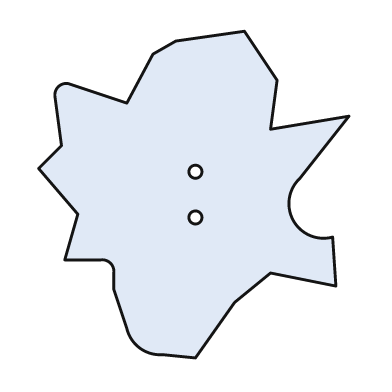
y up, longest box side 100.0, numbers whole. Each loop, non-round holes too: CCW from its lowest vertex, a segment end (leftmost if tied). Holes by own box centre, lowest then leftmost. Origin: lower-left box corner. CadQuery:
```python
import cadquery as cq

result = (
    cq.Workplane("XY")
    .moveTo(48.0, 0.0)
    .lineTo(60.0, 17.0)
    .lineTo(71.0, 26.0)
    .lineTo(91.0, 22.0)
    .lineTo(90.0, 37.0)
    .threePointArc((78.0, 42.0), (80.0, 55.0))
    .lineTo(95.0, 74.0)
    .lineTo(71.0, 70.0)
    .lineTo(73.0, 85.0)
    .lineTo(63.0, 100.0)
    .lineTo(42.0, 97.0)
    .lineTo(35.0, 93.0)
    .lineTo(27.0, 78.0)
    .lineTo(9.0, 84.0)
    .threePointArc((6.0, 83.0), (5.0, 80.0))
    .lineTo(7.0, 65.0)
    .lineTo(0.0, 58.0)
    .lineTo(12.0, 44.0)
    .lineTo(8.0, 30.0)
    .lineTo(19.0, 30.0)
    .threePointArc((22.0, 29.0), (23.0, 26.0))
    .lineTo(23.0, 21.0)
    .lineTo(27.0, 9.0)
    .threePointArc((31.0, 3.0), (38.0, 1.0))
    .close()
    .moveTo(48.0, 43.0)
    .circle(2.0)
    .moveTo(48.0, 57.0)
    .circle(2.0)
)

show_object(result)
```